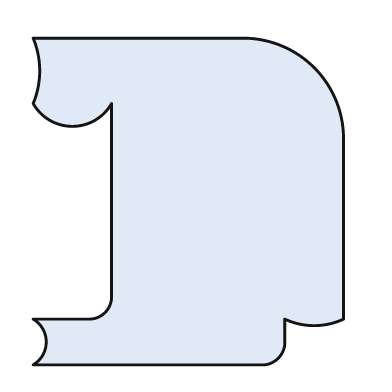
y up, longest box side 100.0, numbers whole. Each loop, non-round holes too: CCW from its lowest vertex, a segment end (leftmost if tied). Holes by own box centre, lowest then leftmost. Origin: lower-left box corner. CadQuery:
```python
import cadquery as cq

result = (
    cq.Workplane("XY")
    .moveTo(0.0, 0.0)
    .lineTo(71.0, 0.0)
    .threePointArc((75.0, 2.0), (77.0, 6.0))
    .lineTo(77.0, 14.0)
    .threePointArc((86.0, 12.0), (95.0, 14.0))
    .lineTo(95.0, 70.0)
    .threePointArc((86.0, 91.0), (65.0, 100.0))
    .lineTo(0.0, 100.0)
    .threePointArc((2.0, 90.0), (0.0, 80.0))
    .threePointArc((12.0, 73.0), (24.0, 80.0))
    .lineTo(24.0, 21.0)
    .threePointArc((22.0, 16.0), (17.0, 14.0))
    .lineTo(0.0, 14.0)
    .threePointArc((4.0, 7.0), (0.0, 0.0))
    .close()
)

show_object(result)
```